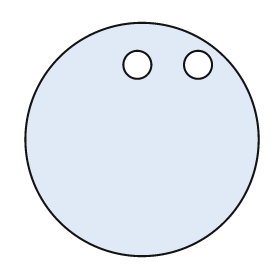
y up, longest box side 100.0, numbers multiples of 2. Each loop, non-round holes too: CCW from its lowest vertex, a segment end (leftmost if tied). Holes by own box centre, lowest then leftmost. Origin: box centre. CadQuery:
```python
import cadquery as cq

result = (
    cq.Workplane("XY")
    .moveTo(0.0, 0.0)
    .circle(50.0)
    .moveTo(-2.0, 32.0)
    .circle(6.0)
    .moveTo(24.0, 32.0)
    .circle(6.0)
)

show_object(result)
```